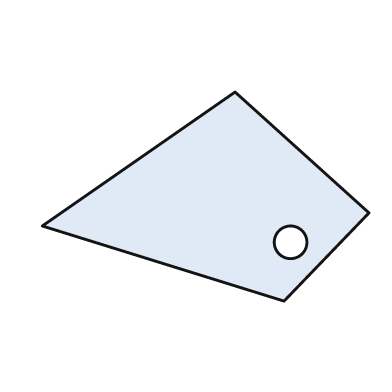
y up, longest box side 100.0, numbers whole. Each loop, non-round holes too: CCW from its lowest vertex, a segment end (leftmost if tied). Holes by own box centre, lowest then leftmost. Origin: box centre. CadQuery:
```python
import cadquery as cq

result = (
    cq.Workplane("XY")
    .moveTo(24.0, -32.0)
    .lineTo(50.0, -5.0)
    .lineTo(9.0, 32.0)
    .lineTo(-50.0, -9.0)
    .close()
    .moveTo(26.0, -14.0)
    .circle(5.0)
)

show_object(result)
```